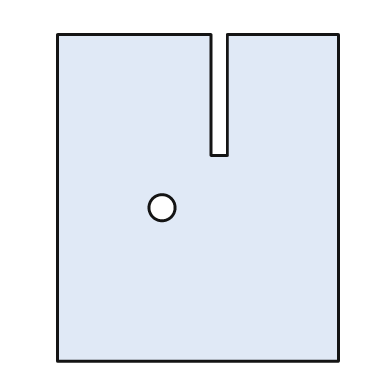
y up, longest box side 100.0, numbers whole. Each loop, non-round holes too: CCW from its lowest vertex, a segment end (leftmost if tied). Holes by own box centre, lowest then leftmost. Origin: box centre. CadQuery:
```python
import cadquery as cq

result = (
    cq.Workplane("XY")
    .moveTo(-43.0, -50.0)
    .lineTo(43.0, -50.0)
    .lineTo(43.0, 50.0)
    .lineTo(9.0, 50.0)
    .lineTo(9.0, 13.0)
    .lineTo(4.0, 13.0)
    .lineTo(4.0, 50.0)
    .lineTo(-43.0, 50.0)
    .close()
    .moveTo(-11.0, -3.0)
    .circle(4.0)
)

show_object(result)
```